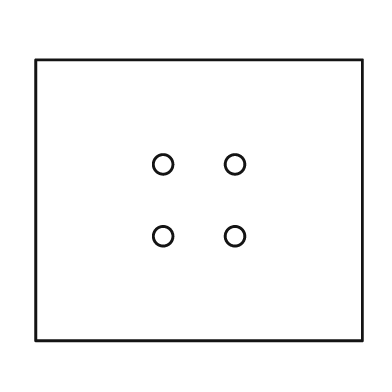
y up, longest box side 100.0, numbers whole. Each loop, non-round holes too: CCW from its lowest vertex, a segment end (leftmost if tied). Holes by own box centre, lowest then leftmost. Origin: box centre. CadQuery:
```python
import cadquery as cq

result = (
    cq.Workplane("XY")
    .moveTo(-50.0, -43.0)
    .lineTo(50.0, -43.0)
    .lineTo(50.0, 43.0)
    .lineTo(-50.0, 43.0)
    .close()
    .moveTo(-11.0, -11.0)
    .circle(3.0)
    .moveTo(11.0, -11.0)
    .circle(3.0)
    .moveTo(-11.0, 11.0)
    .circle(3.0)
    .moveTo(11.0, 11.0)
    .circle(3.0)
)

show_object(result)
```